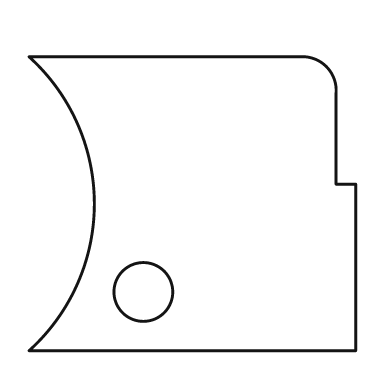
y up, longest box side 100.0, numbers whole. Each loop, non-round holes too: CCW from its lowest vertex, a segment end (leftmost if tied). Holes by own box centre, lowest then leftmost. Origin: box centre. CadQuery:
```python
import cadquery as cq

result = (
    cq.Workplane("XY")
    .moveTo(-50.0, -45.0)
    .lineTo(50.0, -45.0)
    .lineTo(50.0, 6.0)
    .lineTo(44.0, 6.0)
    .lineTo(44.0, 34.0)
    .threePointArc((41.0, 42.0), (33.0, 45.0))
    .lineTo(-50.0, 45.0)
    .threePointArc((-30.0, 0.0), (-50.0, -45.0))
    .close()
    .moveTo(-15.0, -27.0)
    .circle(9.0)
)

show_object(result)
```